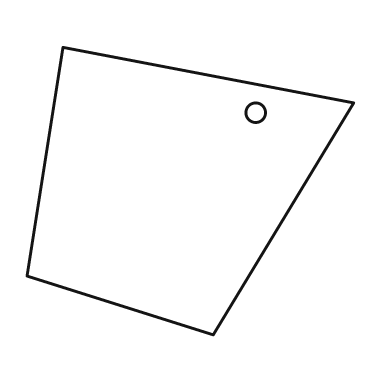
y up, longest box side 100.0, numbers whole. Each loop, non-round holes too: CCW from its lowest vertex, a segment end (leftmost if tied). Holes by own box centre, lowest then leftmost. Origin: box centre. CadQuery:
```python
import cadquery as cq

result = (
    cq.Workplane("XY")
    .moveTo(7.0, -44.0)
    .lineTo(50.0, 27.0)
    .lineTo(-39.0, 44.0)
    .lineTo(-50.0, -26.0)
    .close()
    .moveTo(20.0, 24.0)
    .circle(3.0)
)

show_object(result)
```